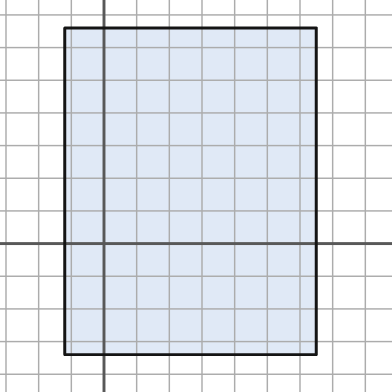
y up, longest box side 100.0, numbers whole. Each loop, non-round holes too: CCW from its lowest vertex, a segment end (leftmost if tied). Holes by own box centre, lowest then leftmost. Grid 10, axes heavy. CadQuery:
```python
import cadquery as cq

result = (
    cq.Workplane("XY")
    .moveTo(-12.0, -34.0)
    .lineTo(65.0, -34.0)
    .lineTo(65.0, 66.0)
    .lineTo(-12.0, 66.0)
    .close()
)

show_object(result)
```